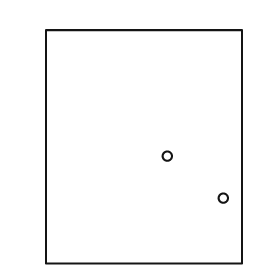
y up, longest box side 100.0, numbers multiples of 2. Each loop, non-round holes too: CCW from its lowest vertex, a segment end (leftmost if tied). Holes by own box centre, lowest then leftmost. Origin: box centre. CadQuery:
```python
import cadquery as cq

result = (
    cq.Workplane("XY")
    .moveTo(-42.0, -50.0)
    .lineTo(42.0, -50.0)
    .lineTo(42.0, 50.0)
    .lineTo(-42.0, 50.0)
    .close()
    .moveTo(34.0, -22.0)
    .circle(2.0)
    .moveTo(10.0, -4.0)
    .circle(2.0)
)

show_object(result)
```